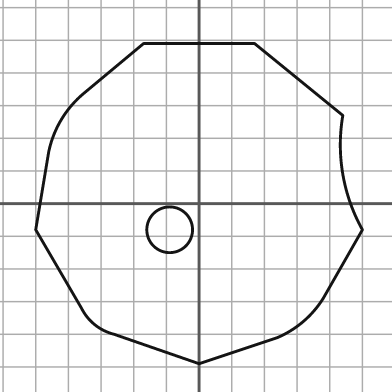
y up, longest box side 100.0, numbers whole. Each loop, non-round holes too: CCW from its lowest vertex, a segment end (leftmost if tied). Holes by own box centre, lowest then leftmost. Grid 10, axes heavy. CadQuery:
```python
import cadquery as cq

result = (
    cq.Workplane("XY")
    .moveTo(0.0, -49.0)
    .lineTo(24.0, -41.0)
    .threePointArc((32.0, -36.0), (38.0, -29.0))
    .lineTo(50.0, -8.0)
    .threePointArc((44.0, 9.0), (44.0, 27.0))
    .lineTo(17.0, 49.0)
    .lineTo(-17.0, 49.0)
    .lineTo(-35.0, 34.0)
    .threePointArc((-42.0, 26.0), (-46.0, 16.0))
    .lineTo(-50.0, -8.0)
    .lineTo(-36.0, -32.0)
    .threePointArc((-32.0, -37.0), (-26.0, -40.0))
    .close()
    .moveTo(-9.0, -8.0)
    .circle(7.0)
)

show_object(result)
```